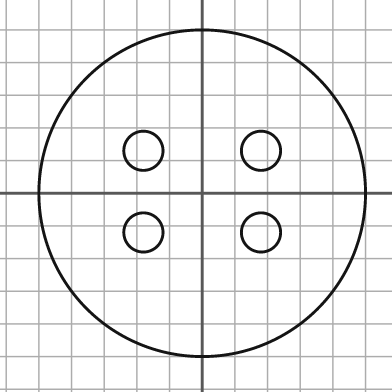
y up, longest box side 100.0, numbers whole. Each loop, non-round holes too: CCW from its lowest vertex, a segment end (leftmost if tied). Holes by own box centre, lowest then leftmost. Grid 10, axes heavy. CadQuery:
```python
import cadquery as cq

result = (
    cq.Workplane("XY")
    .moveTo(0.0, 0.0)
    .circle(50.0)
    .moveTo(-18.0, -12.0)
    .circle(6.0)
    .moveTo(18.0, -12.0)
    .circle(6.0)
    .moveTo(-18.0, 13.0)
    .circle(6.0)
    .moveTo(18.0, 13.0)
    .circle(6.0)
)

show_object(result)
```